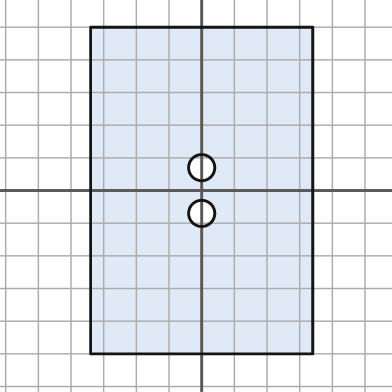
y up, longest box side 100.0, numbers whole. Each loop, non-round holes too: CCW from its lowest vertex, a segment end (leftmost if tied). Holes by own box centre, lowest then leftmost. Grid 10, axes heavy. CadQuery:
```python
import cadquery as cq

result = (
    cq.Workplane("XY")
    .moveTo(-34.0, -50.0)
    .lineTo(34.0, -50.0)
    .lineTo(34.0, 50.0)
    .lineTo(-34.0, 50.0)
    .close()
    .moveTo(0.0, -7.0)
    .circle(4.0)
    .moveTo(0.0, 7.0)
    .circle(4.0)
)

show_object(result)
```